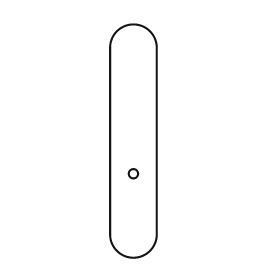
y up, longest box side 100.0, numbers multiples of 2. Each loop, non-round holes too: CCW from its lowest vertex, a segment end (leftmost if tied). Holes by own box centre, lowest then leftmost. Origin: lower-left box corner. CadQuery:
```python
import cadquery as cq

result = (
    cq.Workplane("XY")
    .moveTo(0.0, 10.0)
    .threePointArc((10.0, 0.0), (20.0, 10.0))
    .lineTo(20.0, 90.0)
    .threePointArc((10.0, 100.0), (0.0, 90.0))
    .close()
    .moveTo(10.0, 36.0)
    .circle(2.0)
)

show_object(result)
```